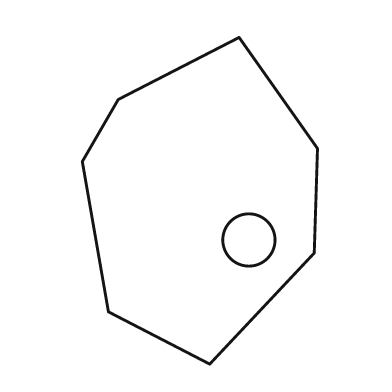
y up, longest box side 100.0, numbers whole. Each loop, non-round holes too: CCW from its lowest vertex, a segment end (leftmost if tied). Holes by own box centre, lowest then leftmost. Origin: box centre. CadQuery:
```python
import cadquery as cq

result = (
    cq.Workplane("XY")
    .moveTo(3.0, -50.0)
    .lineTo(35.0, -16.0)
    .lineTo(36.0, 16.0)
    .lineTo(12.0, 50.0)
    .lineTo(-25.0, 31.0)
    .lineTo(-36.0, 12.0)
    .lineTo(-28.0, -34.0)
    .close()
    .moveTo(15.0, -12.0)
    .circle(8.0)
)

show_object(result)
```